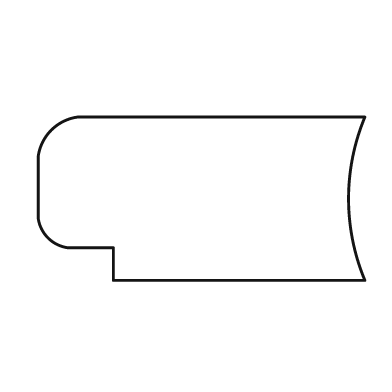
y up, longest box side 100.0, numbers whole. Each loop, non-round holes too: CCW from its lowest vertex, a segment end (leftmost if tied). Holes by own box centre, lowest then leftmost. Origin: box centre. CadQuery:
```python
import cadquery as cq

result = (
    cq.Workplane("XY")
    .moveTo(-27.0, -25.0)
    .lineTo(50.0, -25.0)
    .threePointArc((45.0, 0.0), (50.0, 25.0))
    .lineTo(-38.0, 25.0)
    .threePointArc((-46.0, 21.0), (-50.0, 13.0))
    .lineTo(-50.0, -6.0)
    .threePointArc((-47.0, -12.0), (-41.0, -15.0))
    .lineTo(-27.0, -15.0)
    .close()
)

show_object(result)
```